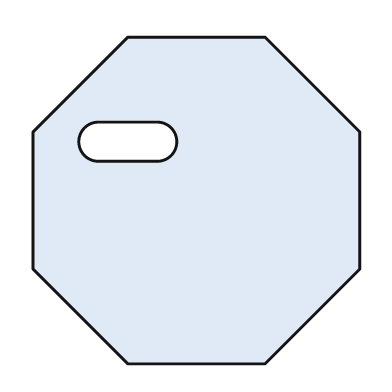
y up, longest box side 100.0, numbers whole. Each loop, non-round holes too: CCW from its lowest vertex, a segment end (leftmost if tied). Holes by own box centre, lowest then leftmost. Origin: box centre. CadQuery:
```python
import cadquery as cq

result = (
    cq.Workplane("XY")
    .moveTo(-21.0, -50.0)
    .lineTo(21.0, -50.0)
    .lineTo(50.0, -21.0)
    .lineTo(50.0, 21.0)
    .lineTo(21.0, 50.0)
    .lineTo(-21.0, 50.0)
    .lineTo(-50.0, 21.0)
    .lineTo(-50.0, -21.0)
    .close()
    .moveTo(-30.0, 12.0)
    .lineTo(-12.0, 12.0)
    .threePointArc((-6.0, 18.0), (-12.0, 24.0))
    .lineTo(-30.0, 24.0)
    .threePointArc((-36.0, 18.0), (-30.0, 12.0))
    .close()
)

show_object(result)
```